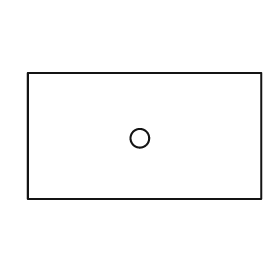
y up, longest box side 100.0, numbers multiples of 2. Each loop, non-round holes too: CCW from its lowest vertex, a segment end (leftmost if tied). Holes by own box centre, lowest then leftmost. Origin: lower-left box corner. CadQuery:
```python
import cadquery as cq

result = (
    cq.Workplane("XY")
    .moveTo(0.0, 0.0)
    .lineTo(100.0, 0.0)
    .lineTo(100.0, 54.0)
    .lineTo(0.0, 54.0)
    .close()
    .moveTo(48.0, 26.0)
    .circle(4.0)
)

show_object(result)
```